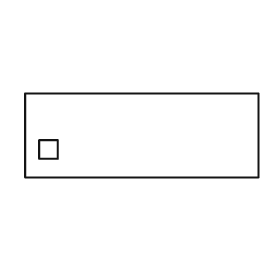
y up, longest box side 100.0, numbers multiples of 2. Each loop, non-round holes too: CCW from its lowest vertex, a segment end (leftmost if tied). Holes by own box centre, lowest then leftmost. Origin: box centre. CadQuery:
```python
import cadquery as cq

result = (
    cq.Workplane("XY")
    .moveTo(-50.0, -18.0)
    .lineTo(50.0, -18.0)
    .lineTo(50.0, 18.0)
    .lineTo(-50.0, 18.0)
    .close()
    .moveTo(-44.0, -10.0)
    .lineTo(-36.0, -10.0)
    .lineTo(-36.0, -2.0)
    .lineTo(-44.0, -2.0)
    .close()
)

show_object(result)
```